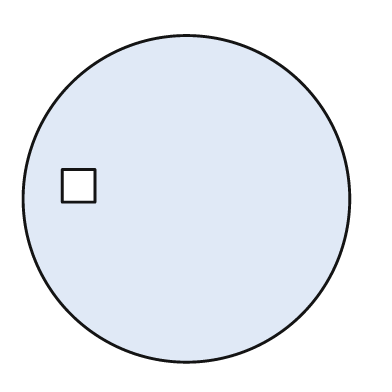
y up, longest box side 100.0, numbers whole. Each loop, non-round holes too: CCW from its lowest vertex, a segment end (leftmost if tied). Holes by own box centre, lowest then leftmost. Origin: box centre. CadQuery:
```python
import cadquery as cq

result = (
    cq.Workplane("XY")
    .moveTo(0.0, 0.0)
    .circle(50.0)
    .moveTo(-38.0, -1.0)
    .lineTo(-28.0, -1.0)
    .lineTo(-28.0, 9.0)
    .lineTo(-38.0, 9.0)
    .close()
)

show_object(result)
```